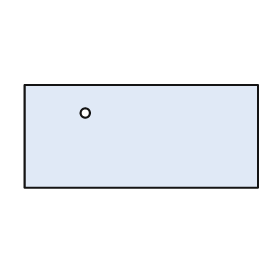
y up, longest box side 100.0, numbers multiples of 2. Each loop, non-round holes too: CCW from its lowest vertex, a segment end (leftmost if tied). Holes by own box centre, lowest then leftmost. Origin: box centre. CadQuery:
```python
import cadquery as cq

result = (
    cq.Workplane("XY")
    .moveTo(-50.0, -22.0)
    .lineTo(50.0, -22.0)
    .lineTo(50.0, 22.0)
    .lineTo(-50.0, 22.0)
    .close()
    .moveTo(-24.0, 10.0)
    .circle(2.0)
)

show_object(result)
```